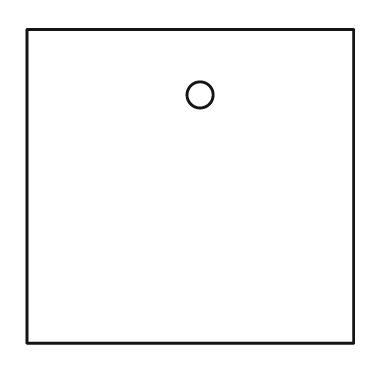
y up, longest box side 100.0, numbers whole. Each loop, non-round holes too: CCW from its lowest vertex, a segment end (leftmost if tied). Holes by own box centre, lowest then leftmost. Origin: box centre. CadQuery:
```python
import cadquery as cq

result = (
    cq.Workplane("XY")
    .moveTo(-50.0, -48.0)
    .lineTo(50.0, -48.0)
    .lineTo(50.0, 48.0)
    .lineTo(-50.0, 48.0)
    .close()
    .moveTo(3.0, 28.0)
    .circle(4.0)
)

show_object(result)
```